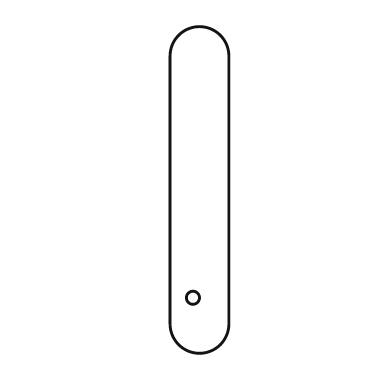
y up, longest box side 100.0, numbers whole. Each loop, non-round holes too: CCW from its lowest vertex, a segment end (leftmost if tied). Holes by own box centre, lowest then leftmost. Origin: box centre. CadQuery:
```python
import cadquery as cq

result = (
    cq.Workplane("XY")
    .moveTo(-9.0, -41.0)
    .threePointArc((0.0, -50.0), (9.0, -41.0))
    .lineTo(9.0, 41.0)
    .threePointArc((0.0, 50.0), (-9.0, 41.0))
    .close()
    .moveTo(-2.0, -33.0)
    .circle(2.0)
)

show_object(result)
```